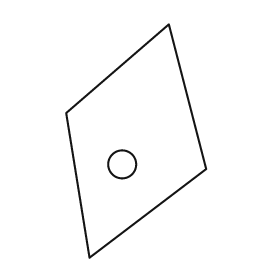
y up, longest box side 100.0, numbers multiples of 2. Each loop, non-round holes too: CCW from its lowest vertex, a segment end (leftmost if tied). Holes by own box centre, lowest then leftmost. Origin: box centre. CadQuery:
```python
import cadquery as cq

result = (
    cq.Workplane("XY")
    .moveTo(-20.0, -50.0)
    .lineTo(30.0, -12.0)
    .lineTo(14.0, 50.0)
    .lineTo(-30.0, 12.0)
    .close()
    .moveTo(-6.0, -10.0)
    .circle(6.0)
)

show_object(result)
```